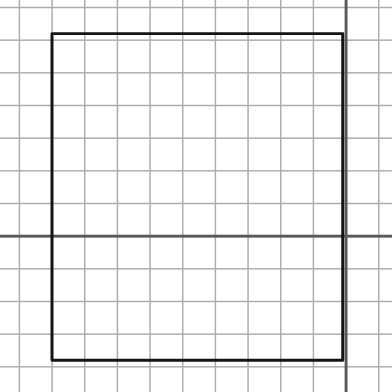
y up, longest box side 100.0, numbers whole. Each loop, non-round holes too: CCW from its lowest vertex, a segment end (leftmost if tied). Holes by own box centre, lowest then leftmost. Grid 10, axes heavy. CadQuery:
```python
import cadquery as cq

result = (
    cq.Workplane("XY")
    .moveTo(-90.0, -38.0)
    .lineTo(-1.0, -38.0)
    .lineTo(-1.0, 62.0)
    .lineTo(-90.0, 62.0)
    .close()
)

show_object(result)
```